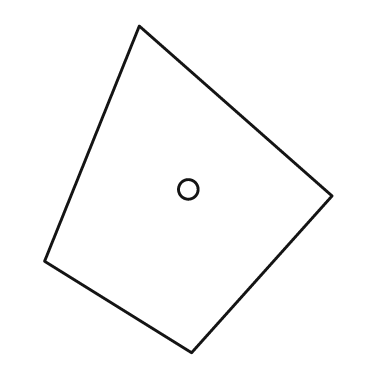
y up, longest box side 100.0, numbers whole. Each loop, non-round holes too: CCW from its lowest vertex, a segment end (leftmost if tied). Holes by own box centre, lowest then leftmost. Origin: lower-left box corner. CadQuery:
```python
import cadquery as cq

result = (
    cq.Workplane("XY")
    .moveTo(45.0, 0.0)
    .lineTo(88.0, 48.0)
    .lineTo(29.0, 100.0)
    .lineTo(0.0, 28.0)
    .close()
    .moveTo(44.0, 50.0)
    .circle(3.0)
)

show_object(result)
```